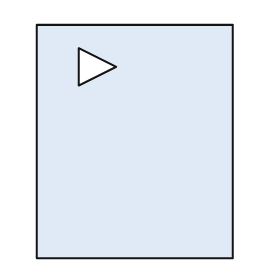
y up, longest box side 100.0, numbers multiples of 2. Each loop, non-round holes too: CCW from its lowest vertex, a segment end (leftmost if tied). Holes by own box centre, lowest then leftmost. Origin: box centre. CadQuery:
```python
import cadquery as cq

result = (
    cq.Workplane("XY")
    .moveTo(-42.0, -50.0)
    .lineTo(42.0, -50.0)
    .lineTo(42.0, 50.0)
    .lineTo(-42.0, 50.0)
    .close()
    .moveTo(-24.0, 24.0)
    .lineTo(-8.0, 32.0)
    .lineTo(-24.0, 40.0)
    .close()
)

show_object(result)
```